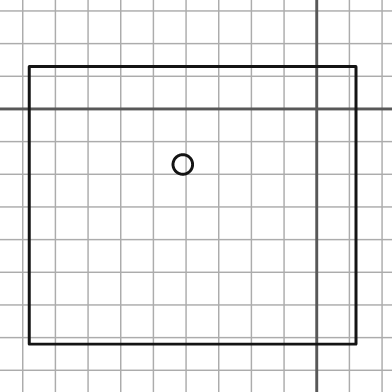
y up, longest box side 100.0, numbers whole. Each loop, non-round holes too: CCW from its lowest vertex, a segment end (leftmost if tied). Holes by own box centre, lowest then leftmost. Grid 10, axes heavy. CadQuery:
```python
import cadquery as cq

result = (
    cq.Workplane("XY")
    .moveTo(-88.0, -72.0)
    .lineTo(12.0, -72.0)
    .lineTo(12.0, 13.0)
    .lineTo(-88.0, 13.0)
    .close()
    .moveTo(-41.0, -17.0)
    .circle(3.0)
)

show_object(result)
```